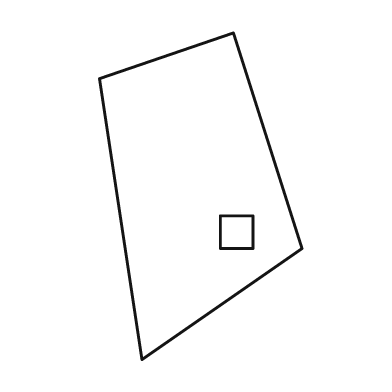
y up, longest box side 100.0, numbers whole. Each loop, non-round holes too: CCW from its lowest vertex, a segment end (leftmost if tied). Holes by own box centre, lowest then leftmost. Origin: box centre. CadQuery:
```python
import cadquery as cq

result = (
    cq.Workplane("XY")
    .moveTo(-18.0, -50.0)
    .lineTo(31.0, -16.0)
    .lineTo(10.0, 50.0)
    .lineTo(-31.0, 36.0)
    .close()
    .moveTo(6.0, -16.0)
    .lineTo(16.0, -16.0)
    .lineTo(16.0, -6.0)
    .lineTo(6.0, -6.0)
    .close()
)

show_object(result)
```